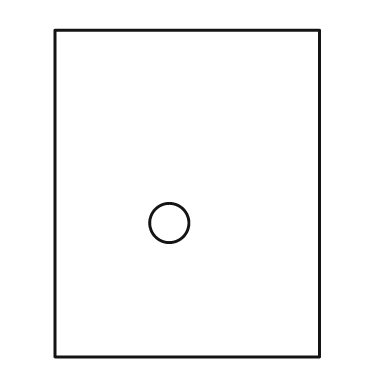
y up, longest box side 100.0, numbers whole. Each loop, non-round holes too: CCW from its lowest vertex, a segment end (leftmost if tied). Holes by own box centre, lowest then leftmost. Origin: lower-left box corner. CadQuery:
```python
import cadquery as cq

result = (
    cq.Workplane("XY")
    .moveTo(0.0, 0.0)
    .lineTo(81.0, 0.0)
    .lineTo(81.0, 100.0)
    .lineTo(0.0, 100.0)
    .close()
    .moveTo(35.0, 41.0)
    .circle(6.0)
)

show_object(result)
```